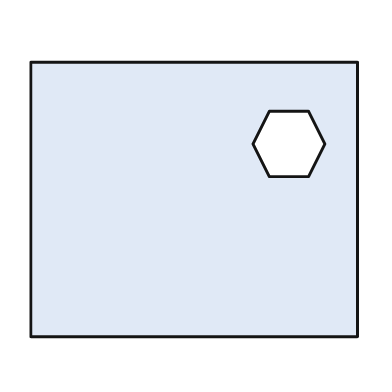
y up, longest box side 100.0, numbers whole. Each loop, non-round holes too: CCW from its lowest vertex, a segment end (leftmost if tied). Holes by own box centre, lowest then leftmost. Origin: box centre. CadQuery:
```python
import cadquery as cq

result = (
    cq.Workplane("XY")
    .moveTo(-50.0, -42.0)
    .lineTo(50.0, -42.0)
    .lineTo(50.0, 42.0)
    .lineTo(-50.0, 42.0)
    .close()
    .moveTo(23.0, 7.0)
    .lineTo(35.0, 7.0)
    .lineTo(40.0, 17.0)
    .lineTo(35.0, 27.0)
    .lineTo(23.0, 27.0)
    .lineTo(18.0, 17.0)
    .close()
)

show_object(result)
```